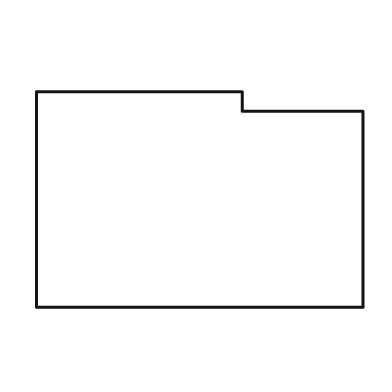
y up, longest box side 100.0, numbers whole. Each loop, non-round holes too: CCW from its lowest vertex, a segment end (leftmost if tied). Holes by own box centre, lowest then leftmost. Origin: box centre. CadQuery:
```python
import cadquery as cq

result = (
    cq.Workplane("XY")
    .moveTo(-50.0, -33.0)
    .lineTo(50.0, -33.0)
    .lineTo(50.0, 27.0)
    .lineTo(13.0, 27.0)
    .lineTo(13.0, 33.0)
    .lineTo(-50.0, 33.0)
    .close()
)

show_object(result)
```